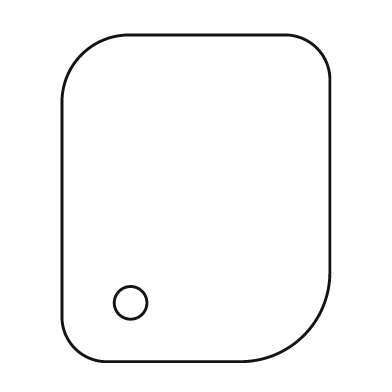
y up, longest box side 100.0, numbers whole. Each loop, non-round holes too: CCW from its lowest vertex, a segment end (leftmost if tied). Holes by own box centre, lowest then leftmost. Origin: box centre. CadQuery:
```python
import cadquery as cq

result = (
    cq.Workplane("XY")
    .moveTo(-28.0, -50.0)
    .lineTo(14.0, -50.0)
    .threePointArc((33.0, -42.0), (41.0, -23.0))
    .lineTo(41.0, 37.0)
    .threePointArc((37.0, 46.0), (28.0, 50.0))
    .lineTo(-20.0, 50.0)
    .threePointArc((-35.0, 44.0), (-41.0, 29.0))
    .lineTo(-41.0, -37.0)
    .threePointArc((-37.0, -46.0), (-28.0, -50.0))
    .close()
    .moveTo(-20.0, -32.0)
    .circle(5.0)
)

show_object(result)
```